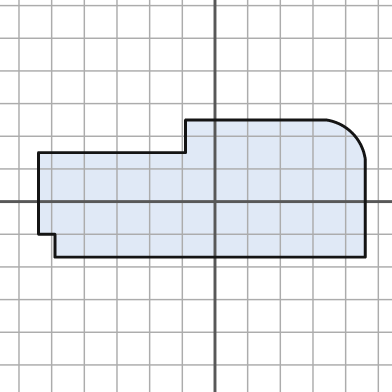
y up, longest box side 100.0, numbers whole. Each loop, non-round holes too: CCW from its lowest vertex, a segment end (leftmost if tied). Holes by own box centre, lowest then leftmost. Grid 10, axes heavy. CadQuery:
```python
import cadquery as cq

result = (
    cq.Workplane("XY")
    .moveTo(-49.0, -17.0)
    .lineTo(46.0, -17.0)
    .lineTo(46.0, 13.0)
    .threePointArc((42.0, 21.0), (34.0, 25.0))
    .lineTo(-9.0, 25.0)
    .lineTo(-9.0, 15.0)
    .lineTo(-54.0, 15.0)
    .lineTo(-54.0, -10.0)
    .lineTo(-49.0, -10.0)
    .close()
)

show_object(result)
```